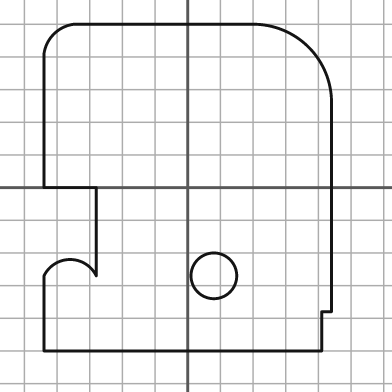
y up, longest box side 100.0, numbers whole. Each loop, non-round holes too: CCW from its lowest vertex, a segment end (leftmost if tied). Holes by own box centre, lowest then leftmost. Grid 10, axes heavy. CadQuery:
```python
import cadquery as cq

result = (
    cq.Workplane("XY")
    .moveTo(-44.0, -50.0)
    .lineTo(41.0, -50.0)
    .lineTo(41.0, -38.0)
    .lineTo(44.0, -38.0)
    .lineTo(44.0, 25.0)
    .threePointArc((37.0, 43.0), (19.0, 50.0))
    .lineTo(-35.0, 50.0)
    .threePointArc((-41.0, 47.0), (-44.0, 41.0))
    .lineTo(-44.0, 0.0)
    .lineTo(-28.0, 0.0)
    .lineTo(-28.0, -27.0)
    .threePointArc((-36.0, -22.0), (-44.0, -27.0))
    .close()
    .moveTo(8.0, -27.0)
    .circle(7.0)
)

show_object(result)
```